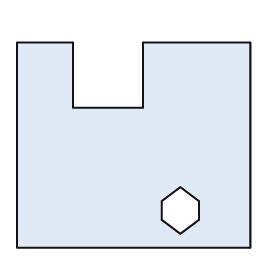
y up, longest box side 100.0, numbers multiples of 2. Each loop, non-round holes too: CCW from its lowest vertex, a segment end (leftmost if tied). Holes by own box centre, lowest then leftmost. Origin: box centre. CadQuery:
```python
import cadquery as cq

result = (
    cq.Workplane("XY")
    .moveTo(-50.0, -44.0)
    .lineTo(50.0, -44.0)
    .lineTo(50.0, 44.0)
    .lineTo(4.0, 44.0)
    .lineTo(4.0, 16.0)
    .lineTo(-26.0, 16.0)
    .lineTo(-26.0, 44.0)
    .lineTo(-50.0, 44.0)
    .close()
    .moveTo(20.0, -38.0)
    .lineTo(28.0, -32.0)
    .lineTo(28.0, -24.0)
    .lineTo(20.0, -18.0)
    .lineTo(12.0, -24.0)
    .lineTo(12.0, -32.0)
    .close()
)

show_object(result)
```